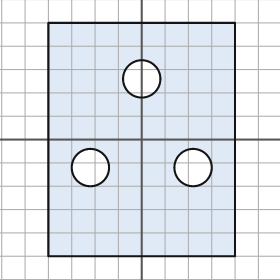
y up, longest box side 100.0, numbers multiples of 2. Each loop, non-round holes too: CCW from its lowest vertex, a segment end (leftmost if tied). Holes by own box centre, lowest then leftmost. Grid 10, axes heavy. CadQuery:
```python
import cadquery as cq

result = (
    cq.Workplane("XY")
    .moveTo(-40.0, -50.0)
    .lineTo(40.0, -50.0)
    .lineTo(40.0, 50.0)
    .lineTo(-40.0, 50.0)
    .close()
    .moveTo(-22.0, -12.0)
    .circle(8.0)
    .moveTo(22.0, -12.0)
    .circle(8.0)
    .moveTo(0.0, 26.0)
    .circle(8.0)
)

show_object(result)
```